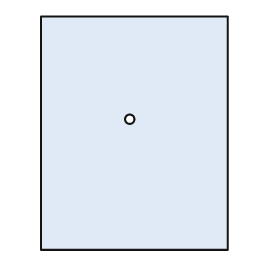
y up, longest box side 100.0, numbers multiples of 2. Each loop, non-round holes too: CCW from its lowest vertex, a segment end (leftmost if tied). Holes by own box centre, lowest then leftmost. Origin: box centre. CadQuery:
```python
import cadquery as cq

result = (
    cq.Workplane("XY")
    .moveTo(-40.0, -50.0)
    .lineTo(40.0, -50.0)
    .lineTo(40.0, 50.0)
    .lineTo(-40.0, 50.0)
    .close()
    .moveTo(-2.0, 6.0)
    .circle(2.0)
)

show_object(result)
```